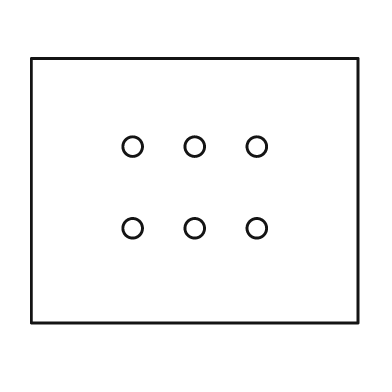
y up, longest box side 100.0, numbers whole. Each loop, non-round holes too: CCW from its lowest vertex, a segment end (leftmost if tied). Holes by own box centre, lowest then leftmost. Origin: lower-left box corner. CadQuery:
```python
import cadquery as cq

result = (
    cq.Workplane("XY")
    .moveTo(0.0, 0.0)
    .lineTo(100.0, 0.0)
    .lineTo(100.0, 81.0)
    .lineTo(0.0, 81.0)
    .close()
    .moveTo(31.0, 29.0)
    .circle(3.0)
    .moveTo(50.0, 29.0)
    .circle(3.0)
    .moveTo(69.0, 29.0)
    .circle(3.0)
    .moveTo(31.0, 54.0)
    .circle(3.0)
    .moveTo(50.0, 54.0)
    .circle(3.0)
    .moveTo(69.0, 54.0)
    .circle(3.0)
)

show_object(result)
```